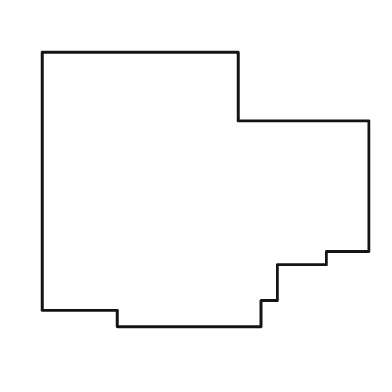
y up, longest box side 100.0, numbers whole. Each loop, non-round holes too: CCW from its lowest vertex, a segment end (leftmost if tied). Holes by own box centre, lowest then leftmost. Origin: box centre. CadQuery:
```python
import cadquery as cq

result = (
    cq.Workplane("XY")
    .moveTo(-27.0, -42.0)
    .lineTo(17.0, -42.0)
    .lineTo(17.0, -34.0)
    .lineTo(22.0, -34.0)
    .lineTo(22.0, -23.0)
    .lineTo(37.0, -23.0)
    .lineTo(37.0, -19.0)
    .lineTo(50.0, -19.0)
    .lineTo(50.0, 21.0)
    .lineTo(10.0, 21.0)
    .lineTo(10.0, 42.0)
    .lineTo(-50.0, 42.0)
    .lineTo(-50.0, -37.0)
    .lineTo(-27.0, -37.0)
    .close()
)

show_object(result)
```